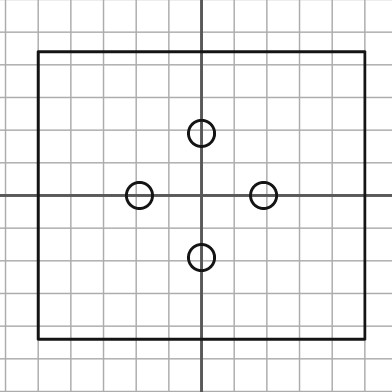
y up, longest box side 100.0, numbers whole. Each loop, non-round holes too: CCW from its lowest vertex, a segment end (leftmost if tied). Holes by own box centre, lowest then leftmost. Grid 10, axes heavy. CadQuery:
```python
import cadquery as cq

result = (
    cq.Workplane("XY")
    .moveTo(-50.0, -44.0)
    .lineTo(50.0, -44.0)
    .lineTo(50.0, 44.0)
    .lineTo(-50.0, 44.0)
    .close()
    .moveTo(0.0, -19.0)
    .circle(4.0)
    .moveTo(-19.0, 0.0)
    .circle(4.0)
    .moveTo(19.0, 0.0)
    .circle(4.0)
    .moveTo(0.0, 19.0)
    .circle(4.0)
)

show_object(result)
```